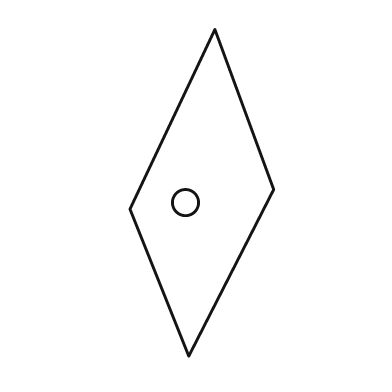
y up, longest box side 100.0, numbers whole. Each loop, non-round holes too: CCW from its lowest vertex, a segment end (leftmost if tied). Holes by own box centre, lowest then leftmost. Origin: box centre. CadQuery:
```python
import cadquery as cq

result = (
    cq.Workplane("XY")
    .moveTo(-4.0, -50.0)
    .lineTo(22.0, 1.0)
    .lineTo(4.0, 50.0)
    .lineTo(-22.0, -5.0)
    .close()
    .moveTo(-5.0, -3.0)
    .circle(4.0)
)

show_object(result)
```